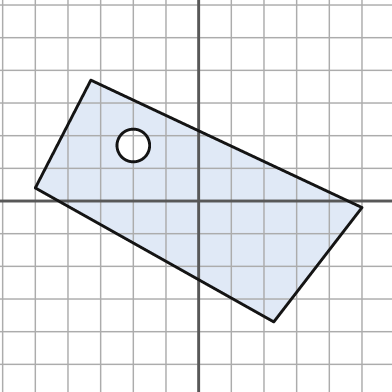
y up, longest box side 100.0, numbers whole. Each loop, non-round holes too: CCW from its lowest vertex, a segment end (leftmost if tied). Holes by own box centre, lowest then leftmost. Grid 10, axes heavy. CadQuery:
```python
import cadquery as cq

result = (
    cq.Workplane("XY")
    .moveTo(23.0, -37.0)
    .lineTo(50.0, -2.0)
    .lineTo(-33.0, 37.0)
    .lineTo(-50.0, 4.0)
    .close()
    .moveTo(-20.0, 17.0)
    .circle(5.0)
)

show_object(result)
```